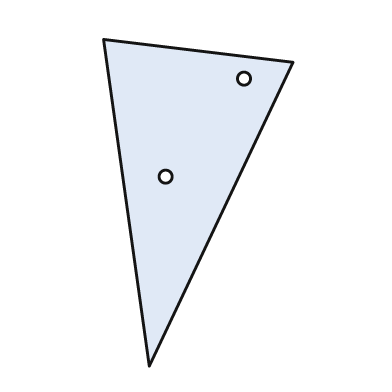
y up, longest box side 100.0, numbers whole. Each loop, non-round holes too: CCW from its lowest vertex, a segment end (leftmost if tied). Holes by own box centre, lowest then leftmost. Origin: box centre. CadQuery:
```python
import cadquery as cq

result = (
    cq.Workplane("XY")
    .moveTo(-15.0, -50.0)
    .lineTo(29.0, 43.0)
    .lineTo(-29.0, 50.0)
    .close()
    .moveTo(-10.0, 8.0)
    .circle(2.0)
    .moveTo(14.0, 38.0)
    .circle(2.0)
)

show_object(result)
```